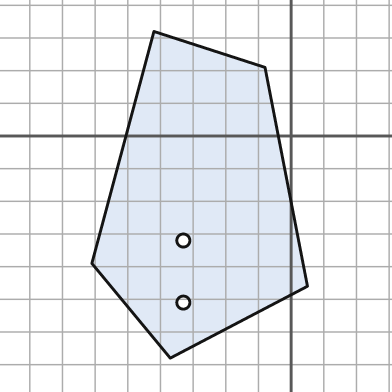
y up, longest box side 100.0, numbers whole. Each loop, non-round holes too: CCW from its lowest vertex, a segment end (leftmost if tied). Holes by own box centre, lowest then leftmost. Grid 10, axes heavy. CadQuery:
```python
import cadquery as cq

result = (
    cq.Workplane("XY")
    .moveTo(-37.0, -68.0)
    .lineTo(5.0, -46.0)
    .lineTo(-8.0, 21.0)
    .lineTo(-42.0, 32.0)
    .lineTo(-61.0, -39.0)
    .close()
    .moveTo(-33.0, -51.0)
    .circle(2.0)
    .moveTo(-33.0, -32.0)
    .circle(2.0)
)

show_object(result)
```